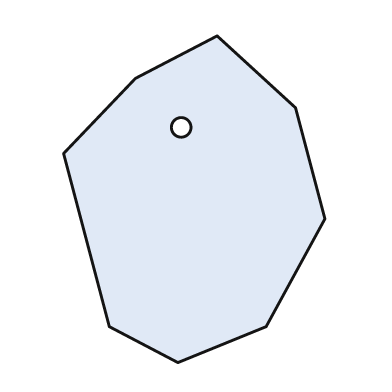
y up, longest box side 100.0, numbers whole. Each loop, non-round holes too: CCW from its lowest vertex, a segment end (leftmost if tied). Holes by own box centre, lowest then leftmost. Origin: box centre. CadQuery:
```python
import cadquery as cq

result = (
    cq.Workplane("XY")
    .moveTo(-5.0, -50.0)
    .lineTo(22.0, -39.0)
    .lineTo(40.0, -6.0)
    .lineTo(31.0, 28.0)
    .lineTo(7.0, 50.0)
    .lineTo(-18.0, 37.0)
    .lineTo(-40.0, 14.0)
    .lineTo(-26.0, -39.0)
    .close()
    .moveTo(-4.0, 22.0)
    .circle(3.0)
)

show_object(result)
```